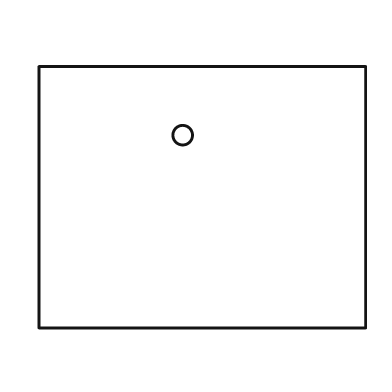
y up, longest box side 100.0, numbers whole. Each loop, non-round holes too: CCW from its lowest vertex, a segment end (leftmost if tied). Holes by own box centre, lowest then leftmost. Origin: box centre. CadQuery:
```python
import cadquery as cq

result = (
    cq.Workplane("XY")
    .moveTo(-50.0, -40.0)
    .lineTo(50.0, -40.0)
    .lineTo(50.0, 40.0)
    .lineTo(-50.0, 40.0)
    .close()
    .moveTo(-6.0, 19.0)
    .circle(3.0)
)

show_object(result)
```